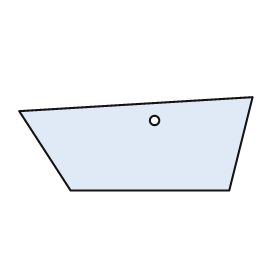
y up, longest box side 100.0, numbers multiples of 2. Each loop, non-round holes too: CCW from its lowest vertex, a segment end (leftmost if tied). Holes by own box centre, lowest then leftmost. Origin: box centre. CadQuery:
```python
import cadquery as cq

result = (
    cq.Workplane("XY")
    .moveTo(-28.0, -20.0)
    .lineTo(40.0, -20.0)
    .lineTo(50.0, 20.0)
    .lineTo(-50.0, 14.0)
    .close()
    .moveTo(8.0, 10.0)
    .circle(2.0)
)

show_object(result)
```